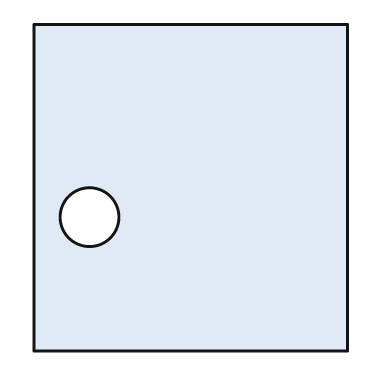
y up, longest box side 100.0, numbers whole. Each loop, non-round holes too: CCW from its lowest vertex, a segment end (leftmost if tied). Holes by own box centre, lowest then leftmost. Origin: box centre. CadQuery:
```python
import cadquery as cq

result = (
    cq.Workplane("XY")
    .moveTo(-48.0, -50.0)
    .lineTo(48.0, -50.0)
    .lineTo(48.0, 50.0)
    .lineTo(-48.0, 50.0)
    .close()
    .moveTo(-31.0, -9.0)
    .circle(9.0)
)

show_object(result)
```